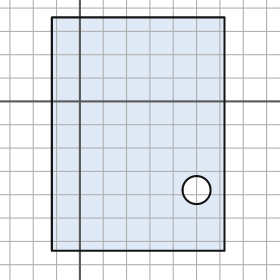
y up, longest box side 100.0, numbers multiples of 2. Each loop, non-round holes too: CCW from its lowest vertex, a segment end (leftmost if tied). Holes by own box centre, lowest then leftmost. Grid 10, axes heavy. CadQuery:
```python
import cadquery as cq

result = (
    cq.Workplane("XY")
    .moveTo(-12.0, -64.0)
    .lineTo(62.0, -64.0)
    .lineTo(62.0, 36.0)
    .lineTo(-12.0, 36.0)
    .close()
    .moveTo(50.0, -38.0)
    .circle(6.0)
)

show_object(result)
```